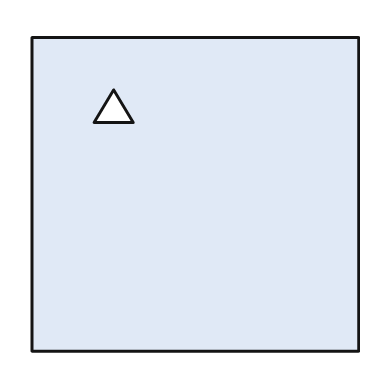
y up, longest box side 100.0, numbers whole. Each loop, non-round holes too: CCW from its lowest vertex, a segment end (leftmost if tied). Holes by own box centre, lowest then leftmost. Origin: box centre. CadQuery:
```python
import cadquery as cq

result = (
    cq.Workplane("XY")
    .moveTo(-50.0, -48.0)
    .lineTo(50.0, -48.0)
    .lineTo(50.0, 48.0)
    .lineTo(-50.0, 48.0)
    .close()
    .moveTo(-31.0, 22.0)
    .lineTo(-19.0, 22.0)
    .lineTo(-25.0, 32.0)
    .close()
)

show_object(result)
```